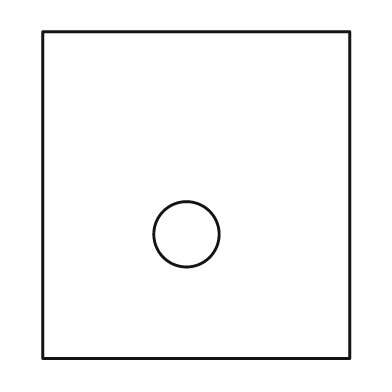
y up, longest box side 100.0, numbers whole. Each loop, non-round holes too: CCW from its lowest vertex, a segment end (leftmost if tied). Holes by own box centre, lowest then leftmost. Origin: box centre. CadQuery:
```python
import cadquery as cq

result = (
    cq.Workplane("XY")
    .moveTo(-47.0, -50.0)
    .lineTo(47.0, -50.0)
    .lineTo(47.0, 50.0)
    .lineTo(-47.0, 50.0)
    .close()
    .moveTo(-3.0, -12.0)
    .circle(10.0)
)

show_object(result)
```